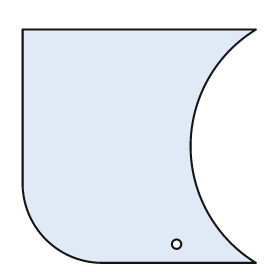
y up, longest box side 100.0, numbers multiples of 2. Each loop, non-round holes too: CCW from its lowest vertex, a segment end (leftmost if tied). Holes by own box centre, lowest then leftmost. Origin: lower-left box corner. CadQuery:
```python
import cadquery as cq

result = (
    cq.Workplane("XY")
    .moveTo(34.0, 0.0)
    .lineTo(100.0, 0.0)
    .threePointArc((72.0, 50.0), (100.0, 100.0))
    .lineTo(0.0, 100.0)
    .lineTo(0.0, 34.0)
    .threePointArc((10.0, 10.0), (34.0, 0.0))
    .close()
    .moveTo(66.0, 8.0)
    .circle(2.0)
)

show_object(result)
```